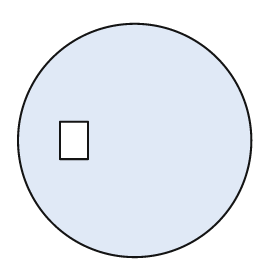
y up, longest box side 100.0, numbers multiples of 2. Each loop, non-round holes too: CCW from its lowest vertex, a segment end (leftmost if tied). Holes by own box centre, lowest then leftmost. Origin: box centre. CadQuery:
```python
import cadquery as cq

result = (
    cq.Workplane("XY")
    .moveTo(0.0, 0.0)
    .circle(50.0)
    .moveTo(-32.0, -8.0)
    .lineTo(-20.0, -8.0)
    .lineTo(-20.0, 8.0)
    .lineTo(-32.0, 8.0)
    .close()
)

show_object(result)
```